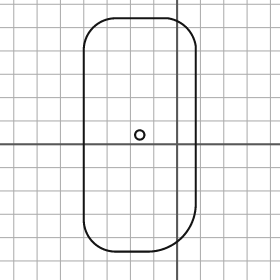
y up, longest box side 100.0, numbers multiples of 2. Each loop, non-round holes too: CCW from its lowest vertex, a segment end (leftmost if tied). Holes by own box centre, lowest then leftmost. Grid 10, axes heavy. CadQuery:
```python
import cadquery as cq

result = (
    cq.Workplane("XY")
    .moveTo(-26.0, -46.0)
    .lineTo(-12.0, -46.0)
    .threePointArc((2.0, -40.0), (8.0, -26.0))
    .lineTo(8.0, 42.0)
    .threePointArc((4.0, 50.0), (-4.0, 54.0))
    .lineTo(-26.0, 54.0)
    .threePointArc((-36.0, 50.0), (-40.0, 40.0))
    .lineTo(-40.0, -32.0)
    .threePointArc((-36.0, -42.0), (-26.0, -46.0))
    .close()
    .moveTo(-16.0, 4.0)
    .circle(2.0)
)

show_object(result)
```